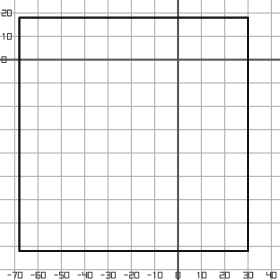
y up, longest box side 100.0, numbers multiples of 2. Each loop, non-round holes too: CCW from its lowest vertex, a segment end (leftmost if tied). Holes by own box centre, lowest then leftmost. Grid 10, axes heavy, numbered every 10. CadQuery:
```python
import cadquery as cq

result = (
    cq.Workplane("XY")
    .moveTo(-68.0, -82.0)
    .lineTo(30.0, -82.0)
    .lineTo(30.0, 18.0)
    .lineTo(-68.0, 18.0)
    .close()
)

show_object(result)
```